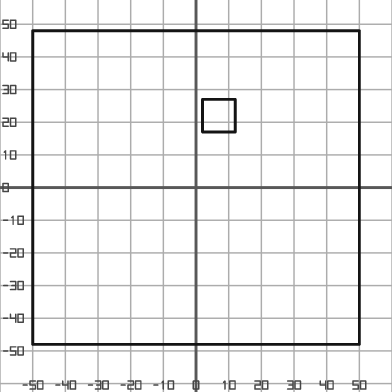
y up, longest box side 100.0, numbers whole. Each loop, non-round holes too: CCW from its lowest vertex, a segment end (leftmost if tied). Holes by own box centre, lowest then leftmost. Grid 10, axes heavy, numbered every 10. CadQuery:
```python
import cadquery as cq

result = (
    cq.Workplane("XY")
    .moveTo(-50.0, -48.0)
    .lineTo(50.0, -48.0)
    .lineTo(50.0, 48.0)
    .lineTo(-50.0, 48.0)
    .close()
    .moveTo(2.0, 17.0)
    .lineTo(12.0, 17.0)
    .lineTo(12.0, 27.0)
    .lineTo(2.0, 27.0)
    .close()
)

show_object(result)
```